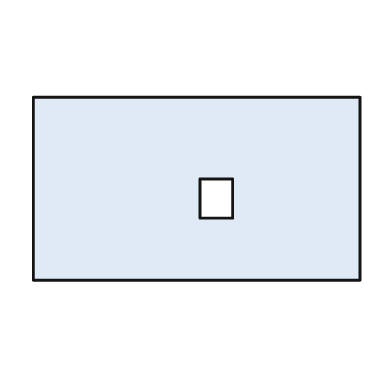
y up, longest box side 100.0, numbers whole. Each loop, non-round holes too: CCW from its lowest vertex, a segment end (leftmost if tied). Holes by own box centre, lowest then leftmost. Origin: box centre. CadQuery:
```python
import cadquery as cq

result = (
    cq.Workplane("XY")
    .moveTo(-50.0, -28.0)
    .lineTo(50.0, -28.0)
    .lineTo(50.0, 28.0)
    .lineTo(-50.0, 28.0)
    .close()
    .moveTo(1.0, -9.0)
    .lineTo(11.0, -9.0)
    .lineTo(11.0, 3.0)
    .lineTo(1.0, 3.0)
    .close()
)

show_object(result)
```